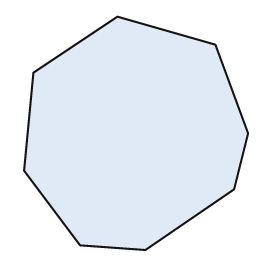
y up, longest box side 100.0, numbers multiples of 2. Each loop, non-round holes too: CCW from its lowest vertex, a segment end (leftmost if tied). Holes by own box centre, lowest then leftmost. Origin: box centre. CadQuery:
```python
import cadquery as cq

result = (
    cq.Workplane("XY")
    .moveTo(4.0, -50.0)
    .lineTo(42.0, -24.0)
    .lineTo(48.0, 0.0)
    .lineTo(34.0, 38.0)
    .lineTo(-8.0, 50.0)
    .lineTo(-44.0, 26.0)
    .lineTo(-48.0, -16.0)
    .lineTo(-24.0, -48.0)
    .close()
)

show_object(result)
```